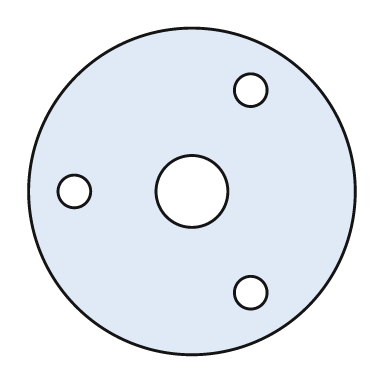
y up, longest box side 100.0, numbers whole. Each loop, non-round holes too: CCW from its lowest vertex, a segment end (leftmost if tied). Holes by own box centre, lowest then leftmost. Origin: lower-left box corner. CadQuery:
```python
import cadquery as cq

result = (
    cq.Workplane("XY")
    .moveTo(50.0, 50.0)
    .circle(50.0)
    .moveTo(68.0, 19.0)
    .circle(5.0)
    .moveTo(14.0, 50.0)
    .circle(5.0)
    .moveTo(50.0, 50.0)
    .circle(11.0)
    .moveTo(68.0, 81.0)
    .circle(5.0)
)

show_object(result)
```